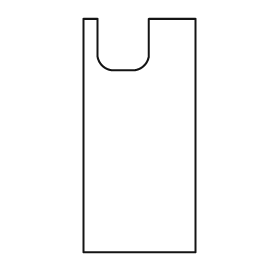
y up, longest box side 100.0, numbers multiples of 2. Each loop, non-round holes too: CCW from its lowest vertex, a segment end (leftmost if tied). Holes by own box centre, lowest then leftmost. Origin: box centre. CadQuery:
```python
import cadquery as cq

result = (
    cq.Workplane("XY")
    .moveTo(-24.0, -50.0)
    .lineTo(24.0, -50.0)
    .lineTo(24.0, 50.0)
    .lineTo(4.0, 50.0)
    .lineTo(4.0, 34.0)
    .threePointArc((2.0, 30.0), (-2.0, 28.0))
    .lineTo(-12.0, 28.0)
    .threePointArc((-16.0, 30.0), (-18.0, 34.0))
    .lineTo(-18.0, 50.0)
    .lineTo(-24.0, 50.0)
    .close()
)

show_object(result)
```